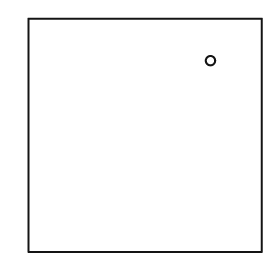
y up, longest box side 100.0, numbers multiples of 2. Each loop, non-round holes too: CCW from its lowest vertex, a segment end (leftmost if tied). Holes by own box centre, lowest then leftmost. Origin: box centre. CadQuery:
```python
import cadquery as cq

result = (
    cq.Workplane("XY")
    .moveTo(-50.0, -50.0)
    .lineTo(50.0, -50.0)
    .lineTo(50.0, 50.0)
    .lineTo(-50.0, 50.0)
    .close()
    .moveTo(28.0, 32.0)
    .circle(2.0)
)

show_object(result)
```